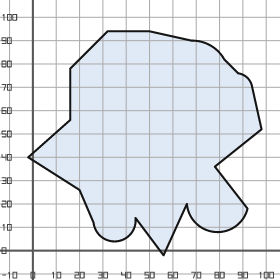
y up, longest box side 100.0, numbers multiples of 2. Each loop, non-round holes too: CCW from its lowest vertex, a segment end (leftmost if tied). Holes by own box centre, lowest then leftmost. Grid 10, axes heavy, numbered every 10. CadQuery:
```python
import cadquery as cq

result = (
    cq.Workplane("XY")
    .moveTo(56.0, -2.0)
    .lineTo(66.0, 20.0)
    .threePointArc((78.0, 8.0), (92.0, 18.0))
    .lineTo(78.0, 36.0)
    .lineTo(98.0, 52.0)
    .lineTo(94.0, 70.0)
    .threePointArc((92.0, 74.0), (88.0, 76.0))
    .lineTo(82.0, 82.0)
    .threePointArc((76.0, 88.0), (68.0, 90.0))
    .lineTo(50.0, 94.0)
    .lineTo(32.0, 94.0)
    .lineTo(16.0, 78.0)
    .lineTo(16.0, 56.0)
    .lineTo(-2.0, 40.0)
    .lineTo(20.0, 26.0)
    .lineTo(26.0, 12.0)
    .threePointArc((36.0, 4.0), (44.0, 14.0))
    .close()
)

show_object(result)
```